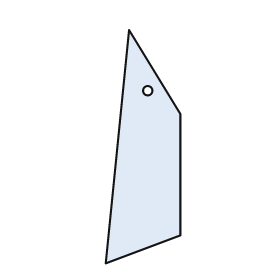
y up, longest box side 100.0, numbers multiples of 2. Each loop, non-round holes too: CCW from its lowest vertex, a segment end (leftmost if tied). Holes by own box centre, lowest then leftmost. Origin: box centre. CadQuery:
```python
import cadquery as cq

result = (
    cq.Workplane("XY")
    .moveTo(-16.0, -50.0)
    .lineTo(16.0, -38.0)
    .lineTo(16.0, 14.0)
    .lineTo(-6.0, 50.0)
    .close()
    .moveTo(2.0, 24.0)
    .circle(2.0)
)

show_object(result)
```